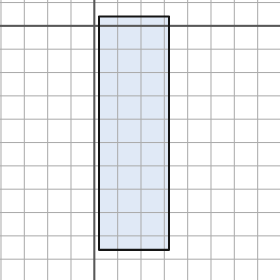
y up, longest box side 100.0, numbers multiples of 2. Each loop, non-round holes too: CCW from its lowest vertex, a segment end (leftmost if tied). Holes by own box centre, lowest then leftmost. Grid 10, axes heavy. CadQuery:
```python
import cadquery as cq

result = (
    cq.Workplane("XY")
    .moveTo(2.0, -96.0)
    .lineTo(32.0, -96.0)
    .lineTo(32.0, 4.0)
    .lineTo(2.0, 4.0)
    .close()
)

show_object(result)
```